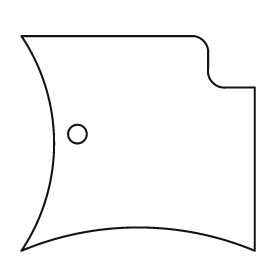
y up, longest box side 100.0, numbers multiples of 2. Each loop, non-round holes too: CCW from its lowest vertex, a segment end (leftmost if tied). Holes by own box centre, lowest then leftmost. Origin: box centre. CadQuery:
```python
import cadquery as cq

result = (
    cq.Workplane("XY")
    .moveTo(-50.0, -46.0)
    .threePointArc((0.0, -36.0), (50.0, -46.0))
    .lineTo(50.0, 24.0)
    .lineTo(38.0, 24.0)
    .threePointArc((32.0, 26.0), (30.0, 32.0))
    .lineTo(30.0, 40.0)
    .threePointArc((28.0, 44.0), (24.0, 46.0))
    .lineTo(-50.0, 46.0)
    .threePointArc((-36.0, 0.0), (-50.0, -46.0))
    .close()
    .moveTo(-26.0, 4.0)
    .circle(4.0)
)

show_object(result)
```